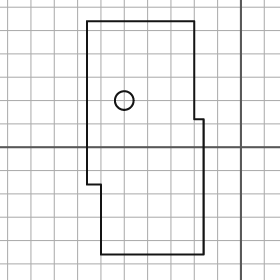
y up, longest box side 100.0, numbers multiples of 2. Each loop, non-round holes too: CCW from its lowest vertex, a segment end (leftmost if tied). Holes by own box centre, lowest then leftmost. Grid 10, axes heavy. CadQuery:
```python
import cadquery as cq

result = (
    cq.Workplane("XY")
    .moveTo(-60.0, -46.0)
    .lineTo(-16.0, -46.0)
    .lineTo(-16.0, 12.0)
    .lineTo(-20.0, 12.0)
    .lineTo(-20.0, 54.0)
    .lineTo(-66.0, 54.0)
    .lineTo(-66.0, -16.0)
    .lineTo(-60.0, -16.0)
    .close()
    .moveTo(-50.0, 20.0)
    .circle(4.0)
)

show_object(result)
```